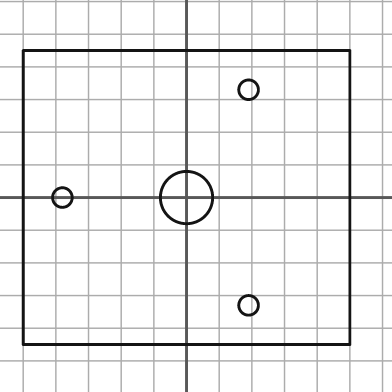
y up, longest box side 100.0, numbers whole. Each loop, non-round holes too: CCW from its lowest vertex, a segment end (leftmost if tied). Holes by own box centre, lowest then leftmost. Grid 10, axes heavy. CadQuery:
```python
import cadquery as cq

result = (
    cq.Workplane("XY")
    .moveTo(-50.0, -45.0)
    .lineTo(50.0, -45.0)
    .lineTo(50.0, 45.0)
    .lineTo(-50.0, 45.0)
    .close()
    .moveTo(19.0, -33.0)
    .circle(3.0)
    .moveTo(-38.0, 0.0)
    .circle(3.0)
    .moveTo(0.0, 0.0)
    .circle(8.0)
    .moveTo(19.0, 33.0)
    .circle(3.0)
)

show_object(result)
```